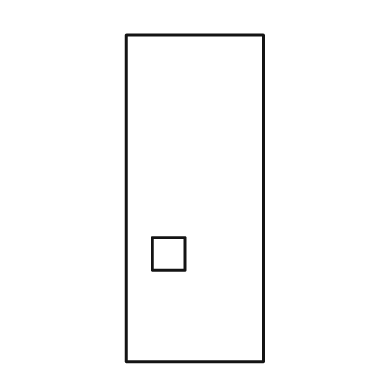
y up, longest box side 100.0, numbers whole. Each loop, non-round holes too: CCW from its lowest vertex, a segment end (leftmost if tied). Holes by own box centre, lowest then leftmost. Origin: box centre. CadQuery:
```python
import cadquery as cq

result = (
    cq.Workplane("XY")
    .moveTo(-21.0, -50.0)
    .lineTo(21.0, -50.0)
    .lineTo(21.0, 50.0)
    .lineTo(-21.0, 50.0)
    .close()
    .moveTo(-13.0, -22.0)
    .lineTo(-3.0, -22.0)
    .lineTo(-3.0, -12.0)
    .lineTo(-13.0, -12.0)
    .close()
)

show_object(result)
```